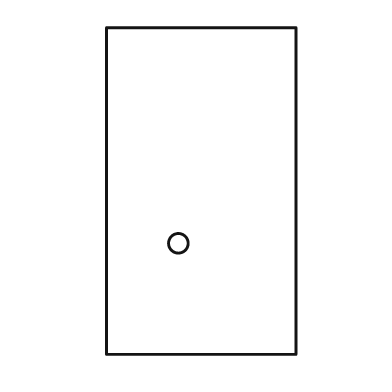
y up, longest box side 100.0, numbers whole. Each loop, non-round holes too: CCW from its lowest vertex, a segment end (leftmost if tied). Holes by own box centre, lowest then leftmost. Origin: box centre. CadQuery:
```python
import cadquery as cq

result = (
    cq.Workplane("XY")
    .moveTo(-29.0, -50.0)
    .lineTo(29.0, -50.0)
    .lineTo(29.0, 50.0)
    .lineTo(-29.0, 50.0)
    .close()
    .moveTo(-7.0, -16.0)
    .circle(3.0)
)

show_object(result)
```